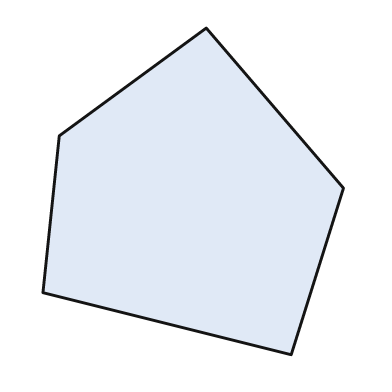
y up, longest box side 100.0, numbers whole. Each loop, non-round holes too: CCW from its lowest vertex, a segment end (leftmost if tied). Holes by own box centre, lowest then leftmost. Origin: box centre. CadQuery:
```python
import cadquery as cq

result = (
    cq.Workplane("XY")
    .moveTo(30.0, -50.0)
    .lineTo(46.0, 1.0)
    .lineTo(4.0, 50.0)
    .lineTo(-41.0, 17.0)
    .lineTo(-46.0, -31.0)
    .close()
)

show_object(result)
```